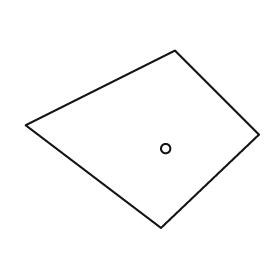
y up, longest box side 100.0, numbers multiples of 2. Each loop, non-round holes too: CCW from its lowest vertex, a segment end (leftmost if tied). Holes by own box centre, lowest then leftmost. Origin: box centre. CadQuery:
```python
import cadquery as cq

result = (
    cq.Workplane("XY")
    .moveTo(8.0, -38.0)
    .lineTo(50.0, 2.0)
    .lineTo(14.0, 38.0)
    .lineTo(-50.0, 6.0)
    .close()
    .moveTo(10.0, -4.0)
    .circle(2.0)
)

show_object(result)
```